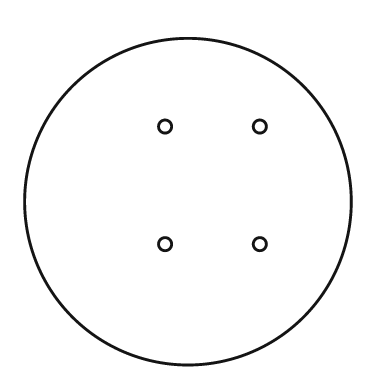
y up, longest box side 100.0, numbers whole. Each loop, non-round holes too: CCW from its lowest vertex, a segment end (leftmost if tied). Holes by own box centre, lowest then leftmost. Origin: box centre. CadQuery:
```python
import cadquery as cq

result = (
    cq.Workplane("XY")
    .moveTo(0.0, 0.0)
    .circle(50.0)
    .moveTo(-7.0, -13.0)
    .circle(2.0)
    .moveTo(22.0, -13.0)
    .circle(2.0)
    .moveTo(-7.0, 23.0)
    .circle(2.0)
    .moveTo(22.0, 23.0)
    .circle(2.0)
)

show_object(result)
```